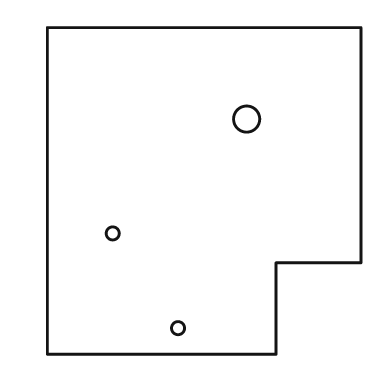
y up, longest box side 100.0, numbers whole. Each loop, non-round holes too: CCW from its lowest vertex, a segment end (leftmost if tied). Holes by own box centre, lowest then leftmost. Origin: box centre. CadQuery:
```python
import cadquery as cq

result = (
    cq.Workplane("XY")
    .moveTo(-48.0, -50.0)
    .lineTo(22.0, -50.0)
    .lineTo(22.0, -22.0)
    .lineTo(48.0, -22.0)
    .lineTo(48.0, 50.0)
    .lineTo(-48.0, 50.0)
    .close()
    .moveTo(-8.0, -42.0)
    .circle(2.0)
    .moveTo(-28.0, -13.0)
    .circle(2.0)
    .moveTo(13.0, 22.0)
    .circle(4.0)
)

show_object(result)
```